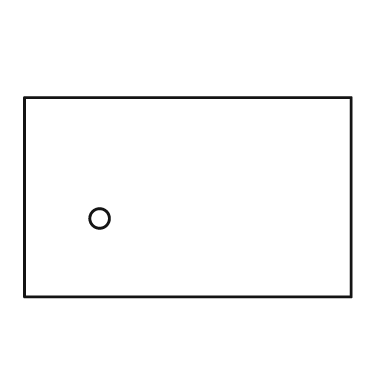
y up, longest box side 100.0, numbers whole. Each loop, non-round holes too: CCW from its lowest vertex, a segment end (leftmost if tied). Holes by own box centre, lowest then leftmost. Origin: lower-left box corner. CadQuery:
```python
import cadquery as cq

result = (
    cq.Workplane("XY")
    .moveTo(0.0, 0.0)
    .lineTo(100.0, 0.0)
    .lineTo(100.0, 61.0)
    .lineTo(0.0, 61.0)
    .close()
    .moveTo(23.0, 24.0)
    .circle(3.0)
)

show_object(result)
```